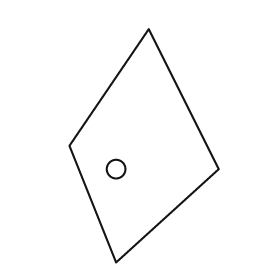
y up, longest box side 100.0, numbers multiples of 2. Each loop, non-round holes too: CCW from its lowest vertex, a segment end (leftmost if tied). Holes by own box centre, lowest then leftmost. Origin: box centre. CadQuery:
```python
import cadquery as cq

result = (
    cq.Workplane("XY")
    .moveTo(-12.0, -50.0)
    .lineTo(32.0, -10.0)
    .lineTo(2.0, 50.0)
    .lineTo(-32.0, 0.0)
    .close()
    .moveTo(-12.0, -10.0)
    .circle(4.0)
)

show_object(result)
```